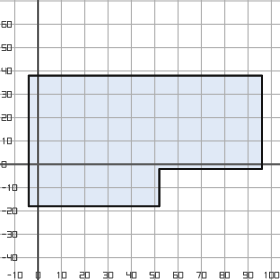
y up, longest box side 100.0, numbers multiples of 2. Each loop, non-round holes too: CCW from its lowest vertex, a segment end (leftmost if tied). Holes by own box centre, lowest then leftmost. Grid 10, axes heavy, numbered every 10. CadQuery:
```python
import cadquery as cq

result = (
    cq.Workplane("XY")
    .moveTo(-4.0, -18.0)
    .lineTo(52.0, -18.0)
    .lineTo(52.0, -2.0)
    .lineTo(96.0, -2.0)
    .lineTo(96.0, 38.0)
    .lineTo(-4.0, 38.0)
    .close()
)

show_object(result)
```